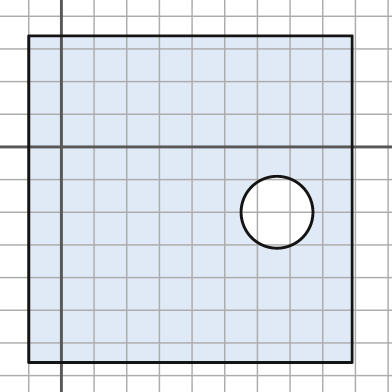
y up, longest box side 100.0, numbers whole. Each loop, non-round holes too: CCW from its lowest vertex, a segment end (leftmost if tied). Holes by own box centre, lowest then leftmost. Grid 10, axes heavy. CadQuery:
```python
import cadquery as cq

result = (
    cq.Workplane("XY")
    .moveTo(-10.0, -66.0)
    .lineTo(89.0, -66.0)
    .lineTo(89.0, 34.0)
    .lineTo(-10.0, 34.0)
    .close()
    .moveTo(66.0, -20.0)
    .circle(11.0)
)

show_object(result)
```